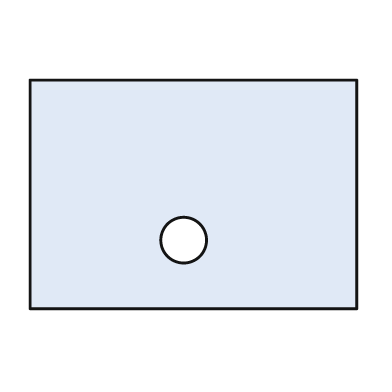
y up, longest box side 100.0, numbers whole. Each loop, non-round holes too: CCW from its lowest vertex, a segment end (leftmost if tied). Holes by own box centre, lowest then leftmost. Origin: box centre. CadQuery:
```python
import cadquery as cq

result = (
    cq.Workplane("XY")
    .moveTo(-50.0, -35.0)
    .lineTo(50.0, -35.0)
    .lineTo(50.0, 35.0)
    .lineTo(-50.0, 35.0)
    .close()
    .moveTo(-3.0, -14.0)
    .circle(7.0)
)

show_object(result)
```